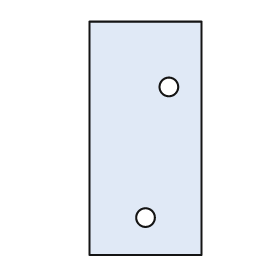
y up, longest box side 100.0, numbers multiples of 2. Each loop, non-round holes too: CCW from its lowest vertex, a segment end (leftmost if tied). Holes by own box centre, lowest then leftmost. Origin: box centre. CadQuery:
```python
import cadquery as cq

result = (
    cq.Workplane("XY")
    .moveTo(-24.0, -50.0)
    .lineTo(24.0, -50.0)
    .lineTo(24.0, 50.0)
    .lineTo(-24.0, 50.0)
    .close()
    .moveTo(0.0, -34.0)
    .circle(4.0)
    .moveTo(10.0, 22.0)
    .circle(4.0)
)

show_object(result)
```